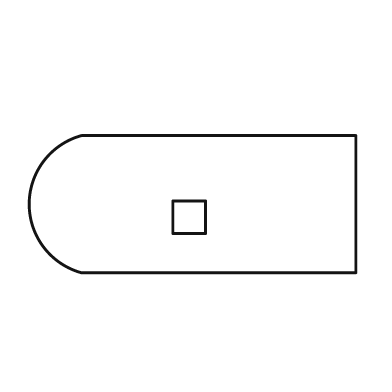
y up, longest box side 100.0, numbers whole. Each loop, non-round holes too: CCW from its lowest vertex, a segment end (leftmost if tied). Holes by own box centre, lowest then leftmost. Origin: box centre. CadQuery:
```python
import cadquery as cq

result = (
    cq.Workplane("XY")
    .moveTo(-34.0, -21.0)
    .lineTo(50.0, -21.0)
    .lineTo(50.0, 21.0)
    .lineTo(-34.0, 21.0)
    .threePointArc((-50.0, 0.0), (-34.0, -21.0))
    .close()
    .moveTo(-6.0, -9.0)
    .lineTo(4.0, -9.0)
    .lineTo(4.0, 1.0)
    .lineTo(-6.0, 1.0)
    .close()
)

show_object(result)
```